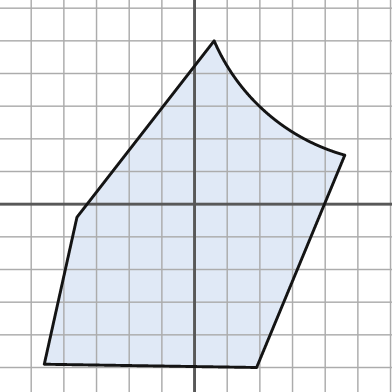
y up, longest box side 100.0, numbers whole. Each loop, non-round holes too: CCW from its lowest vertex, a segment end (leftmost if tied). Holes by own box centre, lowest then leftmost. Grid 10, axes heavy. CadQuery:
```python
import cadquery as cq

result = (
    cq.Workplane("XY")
    .moveTo(19.0, -50.0)
    .lineTo(46.0, 15.0)
    .threePointArc((22.0, 28.0), (6.0, 50.0))
    .lineTo(-36.0, -4.0)
    .lineTo(-46.0, -49.0)
    .close()
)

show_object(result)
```